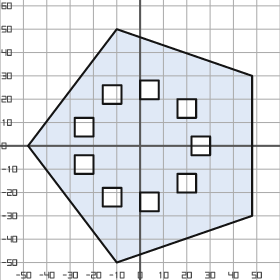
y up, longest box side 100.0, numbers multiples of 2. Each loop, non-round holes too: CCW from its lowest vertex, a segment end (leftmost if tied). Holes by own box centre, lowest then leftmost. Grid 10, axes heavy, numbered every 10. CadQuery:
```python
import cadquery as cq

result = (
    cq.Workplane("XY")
    .moveTo(-10.0, -50.0)
    .lineTo(48.0, -30.0)
    .lineTo(48.0, 30.0)
    .lineTo(-10.0, 50.0)
    .lineTo(-48.0, 0.0)
    .close()
    .moveTo(0.0, -28.0)
    .lineTo(8.0, -28.0)
    .lineTo(8.0, -20.0)
    .lineTo(0.0, -20.0)
    .close()
    .moveTo(-16.0, -26.0)
    .lineTo(-8.0, -26.0)
    .lineTo(-8.0, -18.0)
    .lineTo(-16.0, -18.0)
    .close()
    .moveTo(16.0, -20.0)
    .lineTo(24.0, -20.0)
    .lineTo(24.0, -12.0)
    .lineTo(16.0, -12.0)
    .close()
    .moveTo(-28.0, -12.0)
    .lineTo(-20.0, -12.0)
    .lineTo(-20.0, -4.0)
    .lineTo(-28.0, -4.0)
    .close()
    .moveTo(22.0, -4.0)
    .lineTo(30.0, -4.0)
    .lineTo(30.0, 4.0)
    .lineTo(22.0, 4.0)
    .close()
    .moveTo(-28.0, 4.0)
    .lineTo(-20.0, 4.0)
    .lineTo(-20.0, 12.0)
    .lineTo(-28.0, 12.0)
    .close()
    .moveTo(16.0, 12.0)
    .lineTo(24.0, 12.0)
    .lineTo(24.0, 20.0)
    .lineTo(16.0, 20.0)
    .close()
    .moveTo(-16.0, 18.0)
    .lineTo(-8.0, 18.0)
    .lineTo(-8.0, 26.0)
    .lineTo(-16.0, 26.0)
    .close()
    .moveTo(0.0, 20.0)
    .lineTo(8.0, 20.0)
    .lineTo(8.0, 28.0)
    .lineTo(0.0, 28.0)
    .close()
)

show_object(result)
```